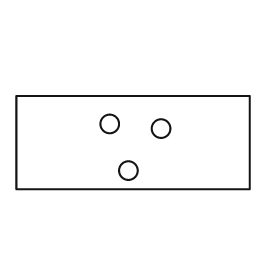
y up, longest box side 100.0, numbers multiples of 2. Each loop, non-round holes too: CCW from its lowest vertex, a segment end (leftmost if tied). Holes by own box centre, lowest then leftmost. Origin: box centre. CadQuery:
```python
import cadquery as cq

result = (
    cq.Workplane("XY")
    .moveTo(-50.0, -20.0)
    .lineTo(50.0, -20.0)
    .lineTo(50.0, 20.0)
    .lineTo(-50.0, 20.0)
    .close()
    .moveTo(-2.0, -12.0)
    .circle(4.0)
    .moveTo(12.0, 6.0)
    .circle(4.0)
    .moveTo(-10.0, 8.0)
    .circle(4.0)
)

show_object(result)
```